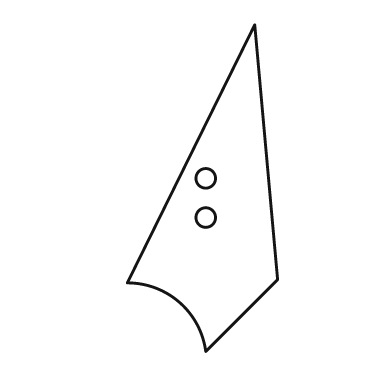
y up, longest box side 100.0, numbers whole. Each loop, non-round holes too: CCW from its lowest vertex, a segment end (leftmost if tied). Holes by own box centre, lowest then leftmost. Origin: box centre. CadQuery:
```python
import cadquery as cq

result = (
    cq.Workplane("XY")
    .moveTo(1.0, -50.0)
    .lineTo(23.0, -28.0)
    .lineTo(16.0, 50.0)
    .lineTo(-23.0, -29.0)
    .threePointArc((-7.0, -35.0), (1.0, -50.0))
    .close()
    .moveTo(1.0, -9.0)
    .circle(3.0)
    .moveTo(1.0, 3.0)
    .circle(3.0)
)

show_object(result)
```